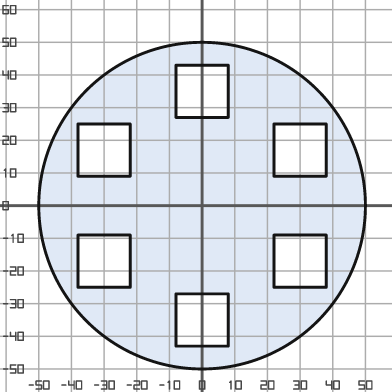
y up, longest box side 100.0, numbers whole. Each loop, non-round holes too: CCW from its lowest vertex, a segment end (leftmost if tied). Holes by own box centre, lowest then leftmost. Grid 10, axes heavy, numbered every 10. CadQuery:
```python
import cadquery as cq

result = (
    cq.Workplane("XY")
    .moveTo(0.0, 0.0)
    .circle(50.0)
    .moveTo(-8.0, -43.0)
    .lineTo(8.0, -43.0)
    .lineTo(8.0, -27.0)
    .lineTo(-8.0, -27.0)
    .close()
    .moveTo(-38.0, -25.0)
    .lineTo(-22.0, -25.0)
    .lineTo(-22.0, -9.0)
    .lineTo(-38.0, -9.0)
    .close()
    .moveTo(22.0, -25.0)
    .lineTo(38.0, -25.0)
    .lineTo(38.0, -9.0)
    .lineTo(22.0, -9.0)
    .close()
    .moveTo(-38.0, 9.0)
    .lineTo(-22.0, 9.0)
    .lineTo(-22.0, 25.0)
    .lineTo(-38.0, 25.0)
    .close()
    .moveTo(22.0, 9.0)
    .lineTo(38.0, 9.0)
    .lineTo(38.0, 25.0)
    .lineTo(22.0, 25.0)
    .close()
    .moveTo(-8.0, 27.0)
    .lineTo(8.0, 27.0)
    .lineTo(8.0, 43.0)
    .lineTo(-8.0, 43.0)
    .close()
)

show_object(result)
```